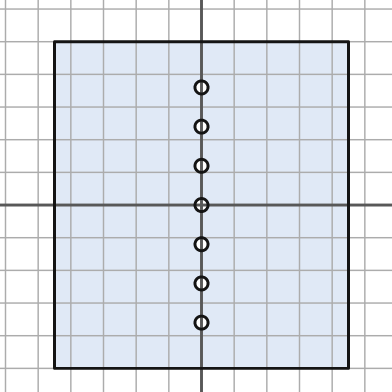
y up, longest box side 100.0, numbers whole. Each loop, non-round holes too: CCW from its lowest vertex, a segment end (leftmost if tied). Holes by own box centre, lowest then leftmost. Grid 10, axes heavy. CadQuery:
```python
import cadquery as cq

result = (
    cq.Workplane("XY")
    .moveTo(-45.0, -50.0)
    .lineTo(45.0, -50.0)
    .lineTo(45.0, 50.0)
    .lineTo(-45.0, 50.0)
    .close()
    .moveTo(0.0, -36.0)
    .circle(2.0)
    .moveTo(0.0, -24.0)
    .circle(2.0)
    .moveTo(0.0, -12.0)
    .circle(2.0)
    .moveTo(0.0, 0.0)
    .circle(2.0)
    .moveTo(0.0, 12.0)
    .circle(2.0)
    .moveTo(0.0, 24.0)
    .circle(2.0)
    .moveTo(0.0, 36.0)
    .circle(2.0)
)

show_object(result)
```